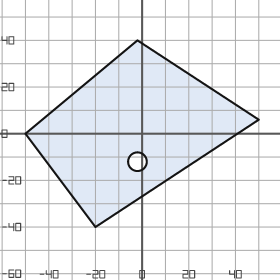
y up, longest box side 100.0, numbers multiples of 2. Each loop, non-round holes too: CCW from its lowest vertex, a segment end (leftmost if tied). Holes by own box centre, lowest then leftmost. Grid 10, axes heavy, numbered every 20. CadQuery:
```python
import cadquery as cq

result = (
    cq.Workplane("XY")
    .moveTo(-20.0, -40.0)
    .lineTo(50.0, 6.0)
    .lineTo(-2.0, 40.0)
    .lineTo(-50.0, 0.0)
    .close()
    .moveTo(-2.0, -12.0)
    .circle(4.0)
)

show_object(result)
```